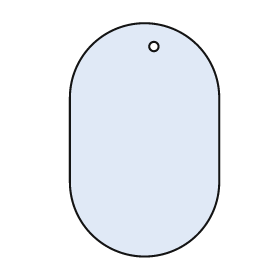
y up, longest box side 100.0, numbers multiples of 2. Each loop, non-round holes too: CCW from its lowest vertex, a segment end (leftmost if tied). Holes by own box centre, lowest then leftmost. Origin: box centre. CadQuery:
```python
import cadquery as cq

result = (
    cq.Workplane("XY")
    .moveTo(-32.0, -18.0)
    .threePointArc((0.0, -50.0), (32.0, -18.0))
    .lineTo(32.0, 18.0)
    .threePointArc((0.0, 50.0), (-32.0, 18.0))
    .close()
    .moveTo(4.0, 40.0)
    .circle(2.0)
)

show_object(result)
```